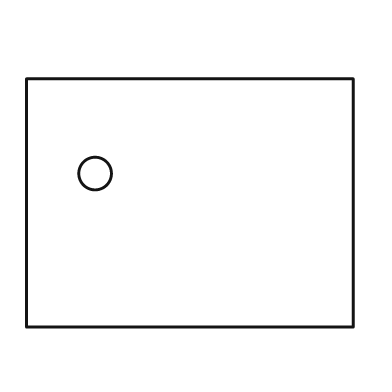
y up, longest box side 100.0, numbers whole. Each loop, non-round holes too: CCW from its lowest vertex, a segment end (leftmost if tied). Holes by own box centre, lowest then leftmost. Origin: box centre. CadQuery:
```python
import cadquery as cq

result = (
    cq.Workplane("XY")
    .moveTo(-50.0, -38.0)
    .lineTo(50.0, -38.0)
    .lineTo(50.0, 38.0)
    .lineTo(-50.0, 38.0)
    .close()
    .moveTo(-29.0, 9.0)
    .circle(5.0)
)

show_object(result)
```